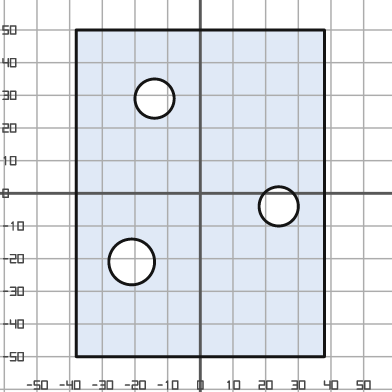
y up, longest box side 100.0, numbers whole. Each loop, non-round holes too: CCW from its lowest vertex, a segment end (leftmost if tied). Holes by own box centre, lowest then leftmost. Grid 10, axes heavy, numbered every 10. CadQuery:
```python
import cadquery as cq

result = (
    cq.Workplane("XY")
    .moveTo(-38.0, -50.0)
    .lineTo(38.0, -50.0)
    .lineTo(38.0, 50.0)
    .lineTo(-38.0, 50.0)
    .close()
    .moveTo(-21.0, -21.0)
    .circle(7.0)
    .moveTo(24.0, -4.0)
    .circle(6.0)
    .moveTo(-14.0, 29.0)
    .circle(6.0)
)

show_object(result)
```